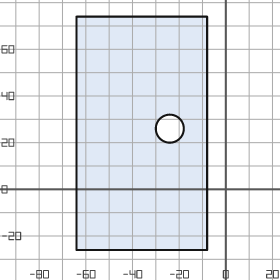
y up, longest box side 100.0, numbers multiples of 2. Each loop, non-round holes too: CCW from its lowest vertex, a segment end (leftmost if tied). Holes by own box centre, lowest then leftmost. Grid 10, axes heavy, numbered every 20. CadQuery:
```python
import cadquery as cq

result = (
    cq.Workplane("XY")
    .moveTo(-64.0, -26.0)
    .lineTo(-8.0, -26.0)
    .lineTo(-8.0, 74.0)
    .lineTo(-64.0, 74.0)
    .close()
    .moveTo(-24.0, 26.0)
    .circle(6.0)
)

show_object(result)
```